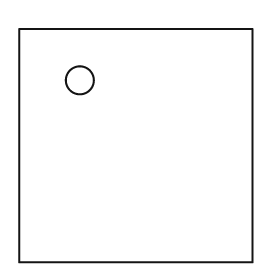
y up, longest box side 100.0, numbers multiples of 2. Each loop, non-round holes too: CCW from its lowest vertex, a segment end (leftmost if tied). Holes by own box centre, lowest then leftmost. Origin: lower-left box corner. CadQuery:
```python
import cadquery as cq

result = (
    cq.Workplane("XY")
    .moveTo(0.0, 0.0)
    .lineTo(100.0, 0.0)
    .lineTo(100.0, 100.0)
    .lineTo(0.0, 100.0)
    .close()
    .moveTo(26.0, 78.0)
    .circle(6.0)
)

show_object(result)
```